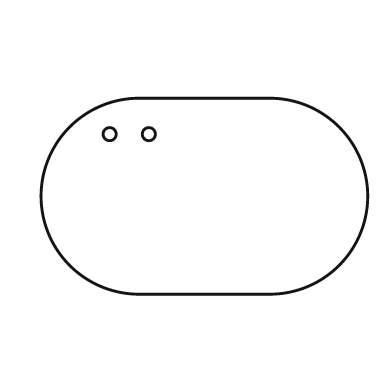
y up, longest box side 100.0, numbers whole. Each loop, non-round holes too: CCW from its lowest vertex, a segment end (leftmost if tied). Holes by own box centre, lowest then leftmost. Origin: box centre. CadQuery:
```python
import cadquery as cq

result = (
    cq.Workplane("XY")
    .moveTo(-20.0, -30.0)
    .lineTo(20.0, -30.0)
    .threePointArc((50.0, 0.0), (20.0, 30.0))
    .lineTo(-20.0, 30.0)
    .threePointArc((-50.0, 0.0), (-20.0, -30.0))
    .close()
    .moveTo(-29.0, 19.0)
    .circle(2.0)
    .moveTo(-17.0, 19.0)
    .circle(2.0)
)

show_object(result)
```